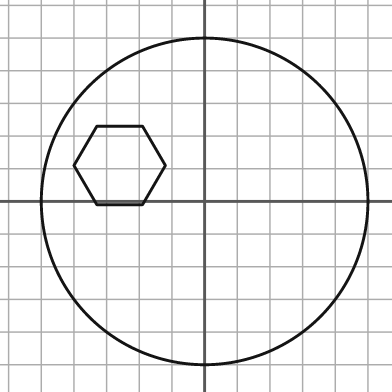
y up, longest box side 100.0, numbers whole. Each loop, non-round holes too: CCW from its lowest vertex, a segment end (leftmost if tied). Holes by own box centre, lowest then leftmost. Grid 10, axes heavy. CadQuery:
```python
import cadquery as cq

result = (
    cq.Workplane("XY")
    .moveTo(0.0, 0.0)
    .circle(50.0)
    .moveTo(-33.0, -1.0)
    .lineTo(-19.0, -1.0)
    .lineTo(-12.0, 11.0)
    .lineTo(-19.0, 23.0)
    .lineTo(-33.0, 23.0)
    .lineTo(-40.0, 11.0)
    .close()
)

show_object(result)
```